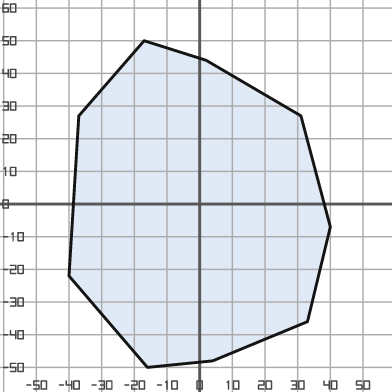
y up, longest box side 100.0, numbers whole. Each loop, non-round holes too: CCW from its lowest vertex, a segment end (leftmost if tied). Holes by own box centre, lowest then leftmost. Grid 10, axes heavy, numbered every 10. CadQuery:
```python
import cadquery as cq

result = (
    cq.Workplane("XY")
    .moveTo(-16.0, -50.0)
    .lineTo(4.0, -48.0)
    .lineTo(33.0, -36.0)
    .lineTo(40.0, -7.0)
    .lineTo(31.0, 27.0)
    .lineTo(2.0, 44.0)
    .lineTo(-17.0, 50.0)
    .lineTo(-37.0, 27.0)
    .lineTo(-40.0, -22.0)
    .close()
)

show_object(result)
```